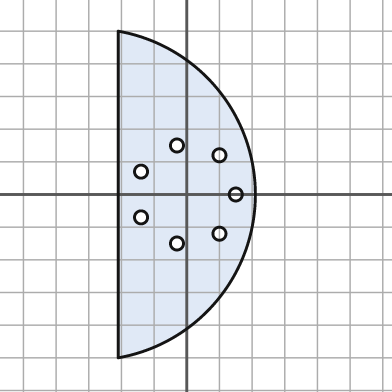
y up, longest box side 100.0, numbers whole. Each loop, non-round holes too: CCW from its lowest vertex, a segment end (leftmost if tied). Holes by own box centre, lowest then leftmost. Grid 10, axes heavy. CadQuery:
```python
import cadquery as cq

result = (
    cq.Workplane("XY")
    .moveTo(-21.0, -50.0)
    .threePointArc((21.0, 0.0), (-21.0, 50.0))
    .close()
    .moveTo(-3.0, -15.0)
    .circle(2.0)
    .moveTo(10.0, -12.0)
    .circle(2.0)
    .moveTo(-14.0, -7.0)
    .circle(2.0)
    .moveTo(15.0, 0.0)
    .circle(2.0)
    .moveTo(-14.0, 7.0)
    .circle(2.0)
    .moveTo(10.0, 12.0)
    .circle(2.0)
    .moveTo(-3.0, 15.0)
    .circle(2.0)
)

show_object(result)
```